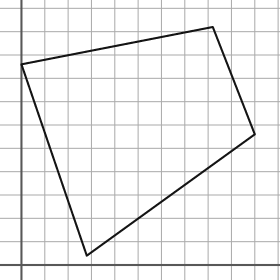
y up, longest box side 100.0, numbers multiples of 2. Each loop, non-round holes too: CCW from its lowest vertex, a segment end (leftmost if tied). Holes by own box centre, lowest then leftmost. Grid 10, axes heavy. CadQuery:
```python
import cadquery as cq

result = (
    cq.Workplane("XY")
    .moveTo(28.0, 4.0)
    .lineTo(100.0, 56.0)
    .lineTo(82.0, 102.0)
    .lineTo(0.0, 86.0)
    .close()
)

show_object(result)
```